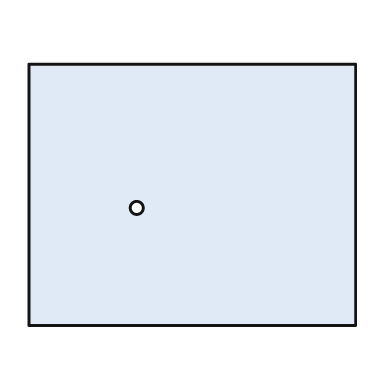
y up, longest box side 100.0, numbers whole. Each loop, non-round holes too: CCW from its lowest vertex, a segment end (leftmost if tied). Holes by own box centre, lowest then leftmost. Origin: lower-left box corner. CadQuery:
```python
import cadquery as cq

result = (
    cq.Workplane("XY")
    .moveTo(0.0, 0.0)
    .lineTo(100.0, 0.0)
    .lineTo(100.0, 80.0)
    .lineTo(0.0, 80.0)
    .close()
    .moveTo(33.0, 36.0)
    .circle(2.0)
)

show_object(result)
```